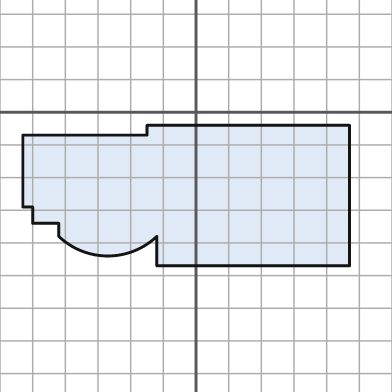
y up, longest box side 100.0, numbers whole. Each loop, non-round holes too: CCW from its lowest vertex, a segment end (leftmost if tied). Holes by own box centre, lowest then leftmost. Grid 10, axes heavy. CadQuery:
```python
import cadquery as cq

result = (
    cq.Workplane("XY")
    .moveTo(-12.0, -47.0)
    .lineTo(47.0, -47.0)
    .lineTo(47.0, -4.0)
    .lineTo(-15.0, -4.0)
    .lineTo(-15.0, -7.0)
    .lineTo(-53.0, -7.0)
    .lineTo(-53.0, -29.0)
    .lineTo(-50.0, -29.0)
    .lineTo(-50.0, -34.0)
    .lineTo(-42.0, -34.0)
    .lineTo(-42.0, -38.0)
    .threePointArc((-27.0, -44.0), (-12.0, -38.0))
    .close()
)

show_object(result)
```